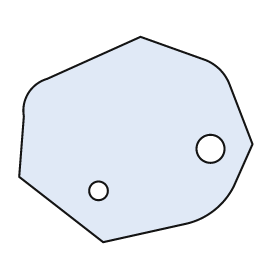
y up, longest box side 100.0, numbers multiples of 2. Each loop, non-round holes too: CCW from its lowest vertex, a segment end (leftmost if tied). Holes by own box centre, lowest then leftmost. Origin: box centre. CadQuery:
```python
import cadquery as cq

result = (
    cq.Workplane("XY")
    .moveTo(-14.0, -44.0)
    .lineTo(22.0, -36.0)
    .threePointArc((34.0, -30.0), (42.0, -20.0))
    .lineTo(50.0, -2.0)
    .lineTo(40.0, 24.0)
    .threePointArc((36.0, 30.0), (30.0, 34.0))
    .lineTo(2.0, 44.0)
    .lineTo(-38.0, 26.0)
    .threePointArc((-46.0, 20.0), (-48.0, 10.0))
    .lineTo(-50.0, -16.0)
    .close()
    .moveTo(-16.0, -22.0)
    .circle(4.0)
    .moveTo(32.0, -4.0)
    .circle(6.0)
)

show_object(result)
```